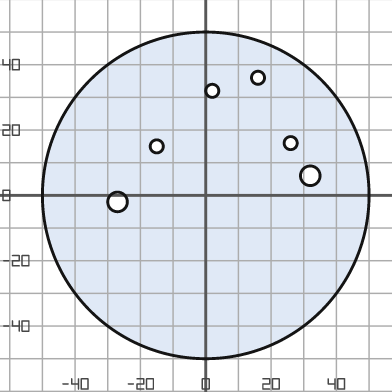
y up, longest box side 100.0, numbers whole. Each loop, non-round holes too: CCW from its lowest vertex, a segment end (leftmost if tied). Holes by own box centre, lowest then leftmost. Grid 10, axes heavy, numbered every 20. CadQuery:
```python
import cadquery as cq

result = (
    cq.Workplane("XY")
    .moveTo(0.0, 0.0)
    .circle(50.0)
    .moveTo(-27.0, -2.0)
    .circle(3.0)
    .moveTo(32.0, 6.0)
    .circle(3.0)
    .moveTo(-15.0, 15.0)
    .circle(2.0)
    .moveTo(26.0, 16.0)
    .circle(2.0)
    .moveTo(2.0, 32.0)
    .circle(2.0)
    .moveTo(16.0, 36.0)
    .circle(2.0)
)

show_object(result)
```